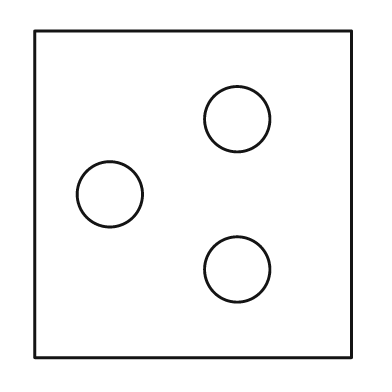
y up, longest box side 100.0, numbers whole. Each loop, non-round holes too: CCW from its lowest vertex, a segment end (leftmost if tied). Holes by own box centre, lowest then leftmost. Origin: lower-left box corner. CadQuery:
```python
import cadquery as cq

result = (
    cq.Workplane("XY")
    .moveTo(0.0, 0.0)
    .lineTo(97.0, 0.0)
    .lineTo(97.0, 100.0)
    .lineTo(0.0, 100.0)
    .close()
    .moveTo(62.0, 27.0)
    .circle(10.0)
    .moveTo(23.0, 50.0)
    .circle(10.0)
    .moveTo(62.0, 73.0)
    .circle(10.0)
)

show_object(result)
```